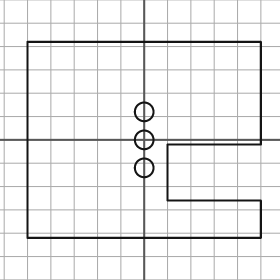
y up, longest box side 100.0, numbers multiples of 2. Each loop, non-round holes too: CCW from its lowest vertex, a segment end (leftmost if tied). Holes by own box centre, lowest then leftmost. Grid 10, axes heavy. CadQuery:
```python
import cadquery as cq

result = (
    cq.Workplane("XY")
    .moveTo(-50.0, -42.0)
    .lineTo(50.0, -42.0)
    .lineTo(50.0, -26.0)
    .lineTo(10.0, -26.0)
    .lineTo(10.0, -2.0)
    .lineTo(50.0, -2.0)
    .lineTo(50.0, 42.0)
    .lineTo(-50.0, 42.0)
    .close()
    .moveTo(0.0, -12.0)
    .circle(4.0)
    .moveTo(0.0, 0.0)
    .circle(4.0)
    .moveTo(0.0, 12.0)
    .circle(4.0)
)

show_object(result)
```